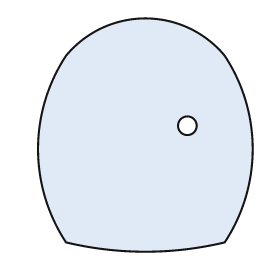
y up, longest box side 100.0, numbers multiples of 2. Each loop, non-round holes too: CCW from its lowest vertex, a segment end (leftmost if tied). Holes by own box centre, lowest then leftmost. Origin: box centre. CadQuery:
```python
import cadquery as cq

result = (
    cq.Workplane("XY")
    .moveTo(-34.0, -46.0)
    .threePointArc((0.0, -50.0), (34.0, -46.0))
    .threePointArc((46.0, -6.0), (34.0, 34.0))
    .threePointArc((0.0, 50.0), (-34.0, 34.0))
    .threePointArc((-46.0, -6.0), (-34.0, -46.0))
    .close()
    .moveTo(18.0, 4.0)
    .circle(4.0)
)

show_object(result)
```